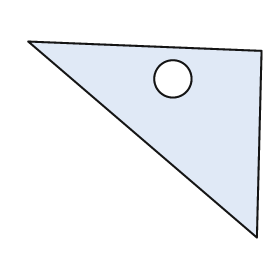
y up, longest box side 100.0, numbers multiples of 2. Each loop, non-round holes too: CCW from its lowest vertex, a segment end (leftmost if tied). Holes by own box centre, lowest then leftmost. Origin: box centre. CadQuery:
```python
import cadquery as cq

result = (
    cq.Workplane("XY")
    .moveTo(48.0, -42.0)
    .lineTo(50.0, 38.0)
    .lineTo(-50.0, 42.0)
    .close()
    .moveTo(12.0, 26.0)
    .circle(8.0)
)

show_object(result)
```